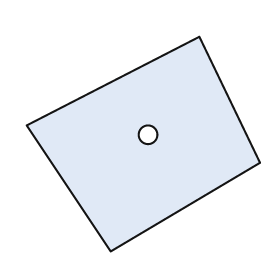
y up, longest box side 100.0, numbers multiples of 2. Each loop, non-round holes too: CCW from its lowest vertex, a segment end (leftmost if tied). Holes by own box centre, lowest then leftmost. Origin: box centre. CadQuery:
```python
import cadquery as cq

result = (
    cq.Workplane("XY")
    .moveTo(-14.0, -46.0)
    .lineTo(50.0, -8.0)
    .lineTo(24.0, 46.0)
    .lineTo(-50.0, 8.0)
    .close()
    .moveTo(2.0, 4.0)
    .circle(4.0)
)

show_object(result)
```